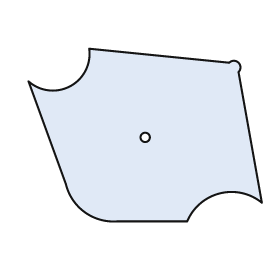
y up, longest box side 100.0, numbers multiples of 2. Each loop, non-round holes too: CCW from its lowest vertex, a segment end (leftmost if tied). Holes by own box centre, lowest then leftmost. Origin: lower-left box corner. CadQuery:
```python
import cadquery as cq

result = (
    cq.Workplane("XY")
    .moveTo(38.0, 0.0)
    .lineTo(68.0, 0.0)
    .threePointArc((82.0, 12.0), (100.0, 8.0))
    .lineTo(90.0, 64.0)
    .threePointArc((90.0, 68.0), (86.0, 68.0))
    .lineTo(26.0, 74.0)
    .threePointArc((18.0, 58.0), (0.0, 60.0))
    .lineTo(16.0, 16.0)
    .threePointArc((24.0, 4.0), (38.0, 0.0))
    .close()
    .moveTo(50.0, 36.0)
    .circle(2.0)
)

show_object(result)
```